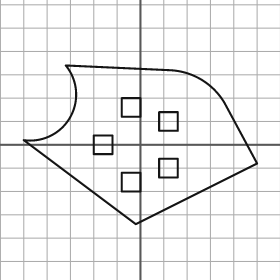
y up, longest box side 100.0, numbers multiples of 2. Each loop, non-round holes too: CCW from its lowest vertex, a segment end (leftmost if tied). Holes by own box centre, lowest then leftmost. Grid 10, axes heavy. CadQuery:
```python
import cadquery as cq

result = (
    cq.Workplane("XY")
    .moveTo(-2.0, -34.0)
    .lineTo(50.0, -8.0)
    .lineTo(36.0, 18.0)
    .threePointArc((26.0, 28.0), (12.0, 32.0))
    .lineTo(-32.0, 34.0)
    .threePointArc((-30.0, 12.0), (-50.0, 2.0))
    .close()
    .moveTo(-8.0, -20.0)
    .lineTo(0.0, -20.0)
    .lineTo(0.0, -12.0)
    .lineTo(-8.0, -12.0)
    .close()
    .moveTo(8.0, -14.0)
    .lineTo(16.0, -14.0)
    .lineTo(16.0, -6.0)
    .lineTo(8.0, -6.0)
    .close()
    .moveTo(-20.0, -4.0)
    .lineTo(-12.0, -4.0)
    .lineTo(-12.0, 4.0)
    .lineTo(-20.0, 4.0)
    .close()
    .moveTo(8.0, 6.0)
    .lineTo(16.0, 6.0)
    .lineTo(16.0, 14.0)
    .lineTo(8.0, 14.0)
    .close()
    .moveTo(-8.0, 12.0)
    .lineTo(0.0, 12.0)
    .lineTo(0.0, 20.0)
    .lineTo(-8.0, 20.0)
    .close()
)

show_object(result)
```